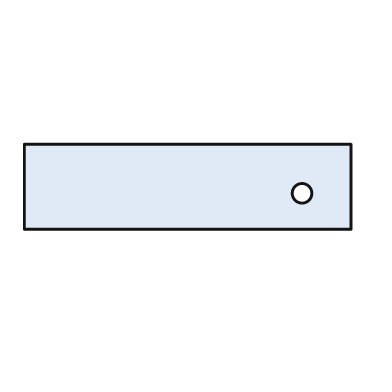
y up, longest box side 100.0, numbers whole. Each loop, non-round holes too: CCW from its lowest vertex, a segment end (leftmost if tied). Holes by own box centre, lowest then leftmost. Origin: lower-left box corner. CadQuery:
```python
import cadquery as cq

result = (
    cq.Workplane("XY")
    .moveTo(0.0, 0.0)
    .lineTo(100.0, 0.0)
    .lineTo(100.0, 26.0)
    .lineTo(0.0, 26.0)
    .close()
    .moveTo(85.0, 11.0)
    .circle(3.0)
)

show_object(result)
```